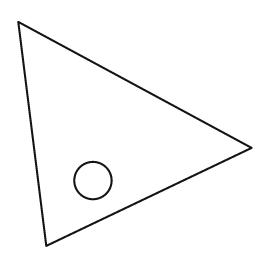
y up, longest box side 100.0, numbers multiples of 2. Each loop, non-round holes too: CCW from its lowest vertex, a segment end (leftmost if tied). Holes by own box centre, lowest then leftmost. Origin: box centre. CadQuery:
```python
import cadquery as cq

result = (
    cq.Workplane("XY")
    .moveTo(-38.0, -48.0)
    .lineTo(50.0, -6.0)
    .lineTo(-50.0, 48.0)
    .close()
    .moveTo(-18.0, -20.0)
    .circle(8.0)
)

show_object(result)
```